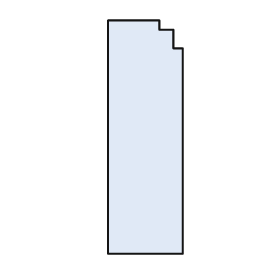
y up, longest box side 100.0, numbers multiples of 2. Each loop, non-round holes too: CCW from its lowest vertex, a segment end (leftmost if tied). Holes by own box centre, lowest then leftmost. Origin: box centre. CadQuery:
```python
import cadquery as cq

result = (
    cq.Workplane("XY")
    .moveTo(-16.0, -50.0)
    .lineTo(16.0, -50.0)
    .lineTo(16.0, 38.0)
    .lineTo(12.0, 38.0)
    .lineTo(12.0, 46.0)
    .lineTo(6.0, 46.0)
    .lineTo(6.0, 50.0)
    .lineTo(-16.0, 50.0)
    .close()
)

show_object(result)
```